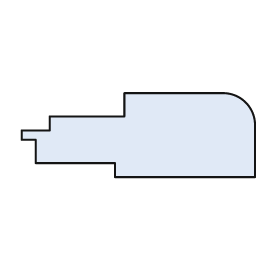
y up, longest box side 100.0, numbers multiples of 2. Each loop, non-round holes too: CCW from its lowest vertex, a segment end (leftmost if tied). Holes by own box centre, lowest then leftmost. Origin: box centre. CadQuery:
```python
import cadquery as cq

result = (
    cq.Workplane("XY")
    .moveTo(-10.0, -18.0)
    .lineTo(50.0, -18.0)
    .lineTo(50.0, 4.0)
    .threePointArc((46.0, 14.0), (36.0, 18.0))
    .lineTo(-6.0, 18.0)
    .lineTo(-6.0, 8.0)
    .lineTo(-38.0, 8.0)
    .lineTo(-38.0, 2.0)
    .lineTo(-50.0, 2.0)
    .lineTo(-50.0, -2.0)
    .lineTo(-44.0, -2.0)
    .lineTo(-44.0, -12.0)
    .lineTo(-10.0, -12.0)
    .close()
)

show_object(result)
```